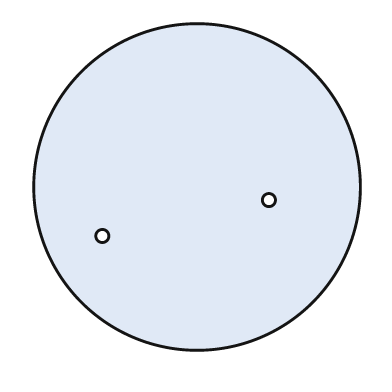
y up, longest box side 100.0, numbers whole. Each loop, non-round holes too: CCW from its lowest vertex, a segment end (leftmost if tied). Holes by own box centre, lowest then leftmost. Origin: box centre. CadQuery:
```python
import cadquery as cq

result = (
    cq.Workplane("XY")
    .moveTo(0.0, 0.0)
    .circle(50.0)
    .moveTo(-29.0, -15.0)
    .circle(2.0)
    .moveTo(22.0, -4.0)
    .circle(2.0)
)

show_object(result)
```